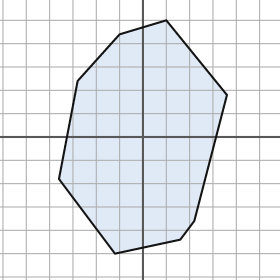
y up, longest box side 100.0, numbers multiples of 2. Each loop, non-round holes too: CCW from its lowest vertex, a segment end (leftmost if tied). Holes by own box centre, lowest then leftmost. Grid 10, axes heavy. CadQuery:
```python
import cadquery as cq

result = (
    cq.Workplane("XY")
    .moveTo(-12.0, -50.0)
    .lineTo(16.0, -44.0)
    .lineTo(22.0, -36.0)
    .lineTo(36.0, 18.0)
    .lineTo(10.0, 50.0)
    .lineTo(-10.0, 44.0)
    .lineTo(-28.0, 24.0)
    .lineTo(-36.0, -18.0)
    .close()
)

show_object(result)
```